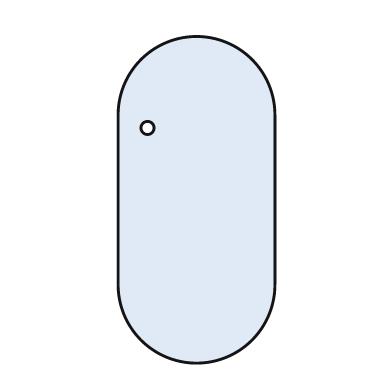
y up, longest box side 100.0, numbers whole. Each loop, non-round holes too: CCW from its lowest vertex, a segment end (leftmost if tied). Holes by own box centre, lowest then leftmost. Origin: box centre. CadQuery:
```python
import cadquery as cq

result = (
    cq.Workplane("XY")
    .moveTo(-24.0, -26.0)
    .threePointArc((0.0, -50.0), (24.0, -26.0))
    .lineTo(24.0, 26.0)
    .threePointArc((0.0, 50.0), (-24.0, 26.0))
    .close()
    .moveTo(-15.0, 22.0)
    .circle(2.0)
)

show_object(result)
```